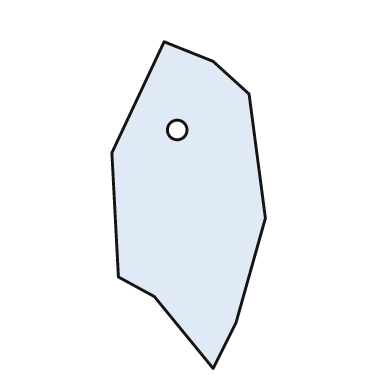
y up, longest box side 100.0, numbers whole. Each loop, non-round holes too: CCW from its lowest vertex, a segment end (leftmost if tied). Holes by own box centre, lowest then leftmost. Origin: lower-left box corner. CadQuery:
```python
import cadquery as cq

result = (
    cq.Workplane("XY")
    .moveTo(31.0, 0.0)
    .lineTo(38.0, 14.0)
    .lineTo(47.0, 46.0)
    .lineTo(42.0, 84.0)
    .lineTo(31.0, 94.0)
    .lineTo(16.0, 100.0)
    .lineTo(0.0, 66.0)
    .lineTo(2.0, 28.0)
    .lineTo(13.0, 22.0)
    .close()
    .moveTo(20.0, 73.0)
    .circle(3.0)
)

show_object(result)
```